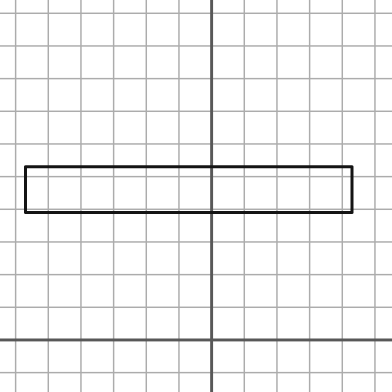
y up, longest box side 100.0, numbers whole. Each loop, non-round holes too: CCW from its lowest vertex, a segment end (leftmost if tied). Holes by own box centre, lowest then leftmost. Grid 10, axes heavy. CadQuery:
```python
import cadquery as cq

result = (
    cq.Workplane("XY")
    .moveTo(-57.0, 39.0)
    .lineTo(43.0, 39.0)
    .lineTo(43.0, 53.0)
    .lineTo(-57.0, 53.0)
    .close()
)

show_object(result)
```